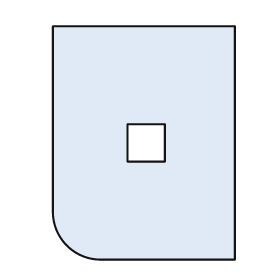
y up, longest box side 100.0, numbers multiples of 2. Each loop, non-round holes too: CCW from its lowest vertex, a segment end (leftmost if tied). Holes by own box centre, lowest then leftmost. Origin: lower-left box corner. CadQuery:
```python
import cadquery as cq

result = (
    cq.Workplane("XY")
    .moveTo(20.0, 0.0)
    .lineTo(78.0, 0.0)
    .lineTo(78.0, 100.0)
    .lineTo(0.0, 100.0)
    .lineTo(0.0, 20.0)
    .threePointArc((6.0, 6.0), (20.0, 0.0))
    .close()
    .moveTo(32.0, 42.0)
    .lineTo(48.0, 42.0)
    .lineTo(48.0, 58.0)
    .lineTo(32.0, 58.0)
    .close()
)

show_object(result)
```